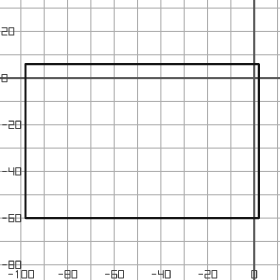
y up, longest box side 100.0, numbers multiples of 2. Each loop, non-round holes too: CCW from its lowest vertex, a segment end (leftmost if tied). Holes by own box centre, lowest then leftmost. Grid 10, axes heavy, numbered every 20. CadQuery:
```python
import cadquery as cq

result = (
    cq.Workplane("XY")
    .moveTo(-98.0, -60.0)
    .lineTo(2.0, -60.0)
    .lineTo(2.0, 6.0)
    .lineTo(-98.0, 6.0)
    .close()
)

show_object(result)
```